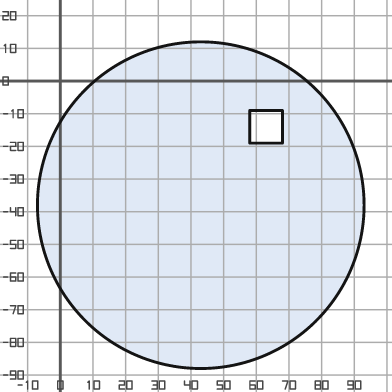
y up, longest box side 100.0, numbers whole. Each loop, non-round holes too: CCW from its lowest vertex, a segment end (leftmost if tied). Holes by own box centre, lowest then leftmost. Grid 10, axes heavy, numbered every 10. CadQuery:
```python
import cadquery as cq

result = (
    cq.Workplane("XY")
    .moveTo(43.0, -38.0)
    .circle(50.0)
    .moveTo(58.0, -19.0)
    .lineTo(68.0, -19.0)
    .lineTo(68.0, -9.0)
    .lineTo(58.0, -9.0)
    .close()
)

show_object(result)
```